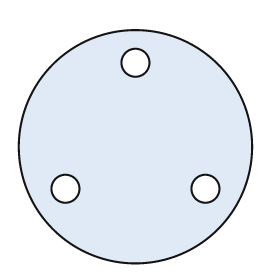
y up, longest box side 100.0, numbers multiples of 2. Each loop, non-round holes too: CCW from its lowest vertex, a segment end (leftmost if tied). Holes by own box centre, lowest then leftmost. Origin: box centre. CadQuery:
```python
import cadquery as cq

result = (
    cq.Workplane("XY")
    .moveTo(0.0, 0.0)
    .circle(50.0)
    .moveTo(-30.0, -18.0)
    .circle(6.0)
    .moveTo(30.0, -18.0)
    .circle(6.0)
    .moveTo(0.0, 36.0)
    .circle(6.0)
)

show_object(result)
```